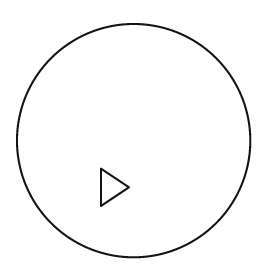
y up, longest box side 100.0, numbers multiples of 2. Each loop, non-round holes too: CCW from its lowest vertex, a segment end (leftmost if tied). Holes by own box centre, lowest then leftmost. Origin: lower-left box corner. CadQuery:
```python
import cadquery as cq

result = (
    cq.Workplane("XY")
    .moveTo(50.0, 50.0)
    .circle(50.0)
    .moveTo(36.0, 22.0)
    .lineTo(48.0, 30.0)
    .lineTo(36.0, 38.0)
    .close()
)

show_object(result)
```